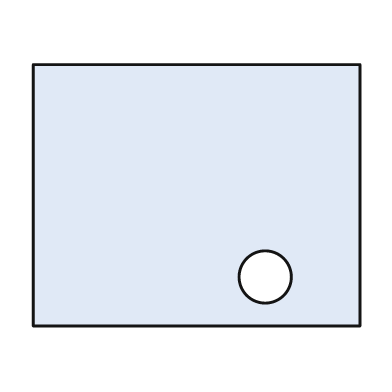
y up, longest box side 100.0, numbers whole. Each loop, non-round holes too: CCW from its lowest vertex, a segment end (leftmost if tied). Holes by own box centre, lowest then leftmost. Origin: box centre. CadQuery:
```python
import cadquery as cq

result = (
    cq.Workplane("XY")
    .moveTo(-50.0, -40.0)
    .lineTo(50.0, -40.0)
    .lineTo(50.0, 40.0)
    .lineTo(-50.0, 40.0)
    .close()
    .moveTo(21.0, -25.0)
    .circle(8.0)
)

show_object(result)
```